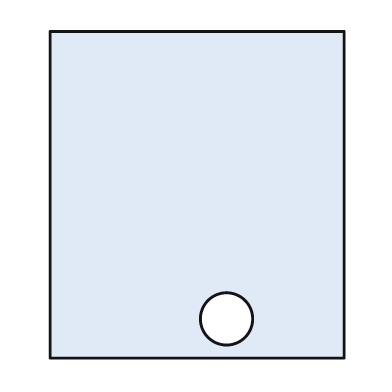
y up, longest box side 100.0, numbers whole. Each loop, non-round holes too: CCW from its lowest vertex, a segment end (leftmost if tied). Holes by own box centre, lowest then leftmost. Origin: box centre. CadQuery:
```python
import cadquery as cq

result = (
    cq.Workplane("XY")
    .moveTo(-45.0, -50.0)
    .lineTo(45.0, -50.0)
    .lineTo(45.0, 50.0)
    .lineTo(-45.0, 50.0)
    .close()
    .moveTo(9.0, -38.0)
    .circle(8.0)
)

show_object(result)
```